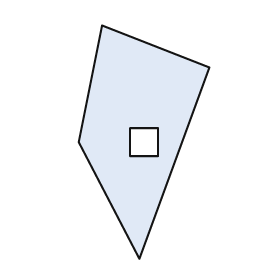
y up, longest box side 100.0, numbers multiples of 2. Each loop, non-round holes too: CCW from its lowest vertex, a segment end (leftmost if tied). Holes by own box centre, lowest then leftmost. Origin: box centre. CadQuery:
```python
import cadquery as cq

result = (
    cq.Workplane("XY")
    .moveTo(-2.0, -50.0)
    .lineTo(28.0, 32.0)
    .lineTo(-18.0, 50.0)
    .lineTo(-28.0, 0.0)
    .close()
    .moveTo(-6.0, -6.0)
    .lineTo(6.0, -6.0)
    .lineTo(6.0, 6.0)
    .lineTo(-6.0, 6.0)
    .close()
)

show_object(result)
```